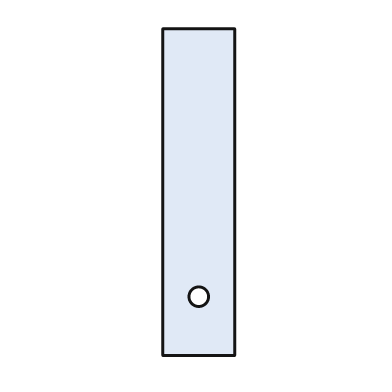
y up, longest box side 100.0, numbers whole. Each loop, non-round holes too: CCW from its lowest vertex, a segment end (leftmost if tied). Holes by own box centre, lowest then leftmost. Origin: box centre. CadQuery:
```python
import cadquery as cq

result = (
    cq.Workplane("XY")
    .moveTo(-11.0, -50.0)
    .lineTo(11.0, -50.0)
    .lineTo(11.0, 50.0)
    .lineTo(-11.0, 50.0)
    .close()
    .moveTo(0.0, -32.0)
    .circle(3.0)
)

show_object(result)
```